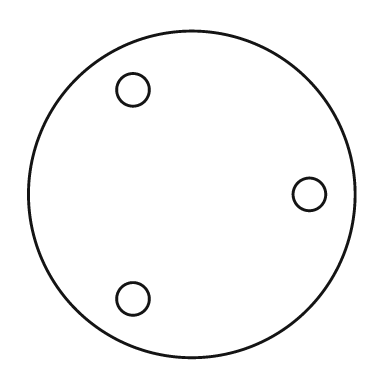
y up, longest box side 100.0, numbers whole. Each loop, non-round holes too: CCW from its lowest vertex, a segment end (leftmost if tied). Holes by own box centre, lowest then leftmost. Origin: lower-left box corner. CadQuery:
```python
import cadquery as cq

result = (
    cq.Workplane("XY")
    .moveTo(50.0, 50.0)
    .circle(50.0)
    .moveTo(32.0, 18.0)
    .circle(5.0)
    .moveTo(86.0, 50.0)
    .circle(5.0)
    .moveTo(32.0, 82.0)
    .circle(5.0)
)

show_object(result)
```